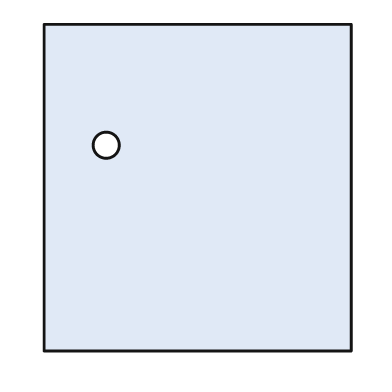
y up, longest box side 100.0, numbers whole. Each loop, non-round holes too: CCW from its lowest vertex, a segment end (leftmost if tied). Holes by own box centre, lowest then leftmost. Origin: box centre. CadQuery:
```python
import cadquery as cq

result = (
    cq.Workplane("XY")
    .moveTo(-47.0, -50.0)
    .lineTo(47.0, -50.0)
    .lineTo(47.0, 50.0)
    .lineTo(-47.0, 50.0)
    .close()
    .moveTo(-28.0, 13.0)
    .circle(4.0)
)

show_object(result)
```